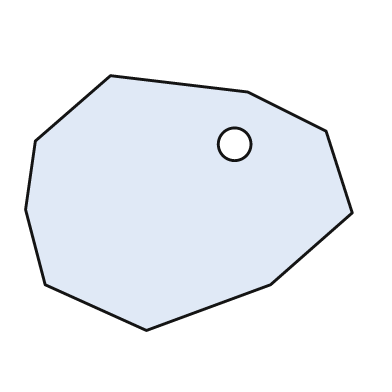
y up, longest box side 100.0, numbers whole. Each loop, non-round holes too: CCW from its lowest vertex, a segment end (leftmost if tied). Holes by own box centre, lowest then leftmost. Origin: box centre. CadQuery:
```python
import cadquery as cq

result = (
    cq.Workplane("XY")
    .moveTo(-13.0, -39.0)
    .lineTo(25.0, -25.0)
    .lineTo(50.0, -3.0)
    .lineTo(42.0, 22.0)
    .lineTo(18.0, 34.0)
    .lineTo(-24.0, 39.0)
    .lineTo(-47.0, 19.0)
    .lineTo(-50.0, -2.0)
    .lineTo(-44.0, -25.0)
    .close()
    .moveTo(14.0, 18.0)
    .circle(5.0)
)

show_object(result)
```